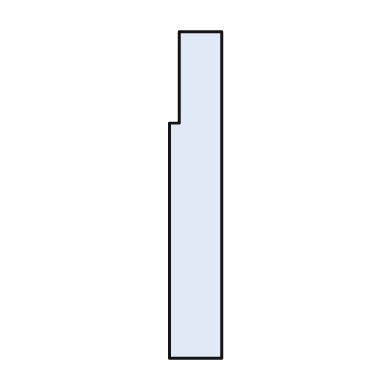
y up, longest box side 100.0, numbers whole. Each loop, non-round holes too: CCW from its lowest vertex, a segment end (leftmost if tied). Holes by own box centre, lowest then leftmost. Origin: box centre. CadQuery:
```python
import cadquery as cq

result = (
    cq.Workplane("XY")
    .moveTo(-8.0, -50.0)
    .lineTo(8.0, -50.0)
    .lineTo(8.0, 50.0)
    .lineTo(-5.0, 50.0)
    .lineTo(-5.0, 22.0)
    .lineTo(-8.0, 22.0)
    .close()
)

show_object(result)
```